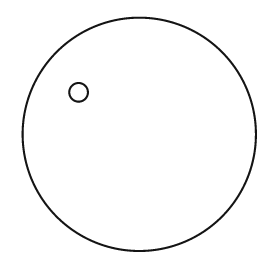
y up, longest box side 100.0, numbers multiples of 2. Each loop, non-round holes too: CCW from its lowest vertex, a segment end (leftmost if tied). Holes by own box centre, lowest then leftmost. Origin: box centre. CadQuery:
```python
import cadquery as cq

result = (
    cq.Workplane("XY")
    .moveTo(0.0, 0.0)
    .circle(50.0)
    .moveTo(-26.0, 18.0)
    .circle(4.0)
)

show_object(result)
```